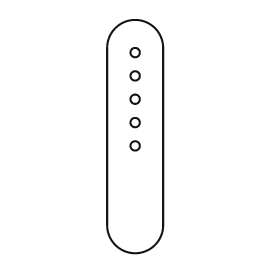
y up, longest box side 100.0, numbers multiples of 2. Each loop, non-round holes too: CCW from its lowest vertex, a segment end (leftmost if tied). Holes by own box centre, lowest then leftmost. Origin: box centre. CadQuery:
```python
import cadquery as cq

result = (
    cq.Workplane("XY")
    .moveTo(-12.0, -38.0)
    .threePointArc((0.0, -50.0), (12.0, -38.0))
    .lineTo(12.0, 38.0)
    .threePointArc((0.0, 50.0), (-12.0, 38.0))
    .close()
    .moveTo(0.0, -4.0)
    .circle(2.0)
    .moveTo(0.0, 6.0)
    .circle(2.0)
    .moveTo(0.0, 16.0)
    .circle(2.0)
    .moveTo(0.0, 26.0)
    .circle(2.0)
    .moveTo(0.0, 36.0)
    .circle(2.0)
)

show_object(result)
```